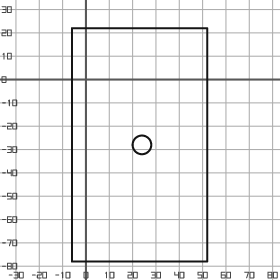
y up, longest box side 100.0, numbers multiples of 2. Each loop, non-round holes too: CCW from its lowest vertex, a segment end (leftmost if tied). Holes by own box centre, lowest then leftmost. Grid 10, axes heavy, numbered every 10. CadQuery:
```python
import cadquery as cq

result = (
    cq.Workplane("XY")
    .moveTo(-6.0, -78.0)
    .lineTo(52.0, -78.0)
    .lineTo(52.0, 22.0)
    .lineTo(-6.0, 22.0)
    .close()
    .moveTo(24.0, -28.0)
    .circle(4.0)
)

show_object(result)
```